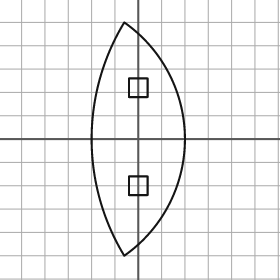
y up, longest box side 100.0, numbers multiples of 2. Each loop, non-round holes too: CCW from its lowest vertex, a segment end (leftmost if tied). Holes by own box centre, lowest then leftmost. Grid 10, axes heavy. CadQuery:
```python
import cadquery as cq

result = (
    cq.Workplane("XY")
    .moveTo(-6.0, -50.0)
    .threePointArc((20.0, 0.0), (-6.0, 50.0))
    .threePointArc((-20.0, 0.0), (-6.0, -50.0))
    .close()
    .moveTo(-4.0, -24.0)
    .lineTo(4.0, -24.0)
    .lineTo(4.0, -16.0)
    .lineTo(-4.0, -16.0)
    .close()
    .moveTo(-4.0, 18.0)
    .lineTo(4.0, 18.0)
    .lineTo(4.0, 26.0)
    .lineTo(-4.0, 26.0)
    .close()
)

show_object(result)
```